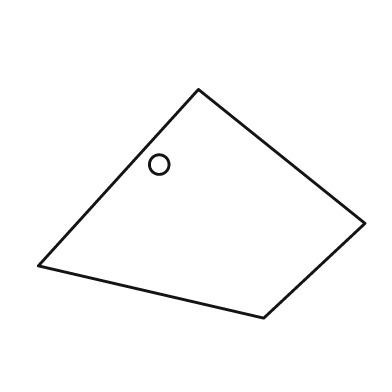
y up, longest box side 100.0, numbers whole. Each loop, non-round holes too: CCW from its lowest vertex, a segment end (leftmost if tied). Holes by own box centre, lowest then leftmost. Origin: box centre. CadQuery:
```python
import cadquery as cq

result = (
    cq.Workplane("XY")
    .moveTo(19.0, -35.0)
    .lineTo(50.0, -6.0)
    .lineTo(-1.0, 35.0)
    .lineTo(-50.0, -19.0)
    .close()
    .moveTo(-13.0, 12.0)
    .circle(3.0)
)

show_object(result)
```